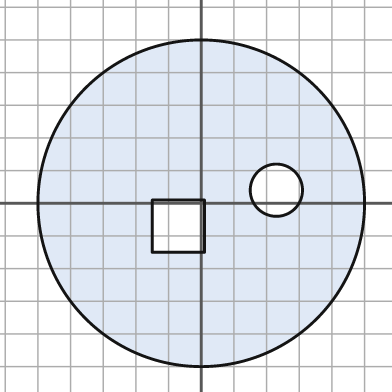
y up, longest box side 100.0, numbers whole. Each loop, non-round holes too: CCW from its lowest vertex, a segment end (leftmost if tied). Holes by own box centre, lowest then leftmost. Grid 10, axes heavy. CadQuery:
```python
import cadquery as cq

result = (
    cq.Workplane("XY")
    .moveTo(0.0, 0.0)
    .circle(50.0)
    .moveTo(-15.0, -15.0)
    .lineTo(1.0, -15.0)
    .lineTo(1.0, 1.0)
    .lineTo(-15.0, 1.0)
    .close()
    .moveTo(23.0, 4.0)
    .circle(8.0)
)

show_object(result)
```